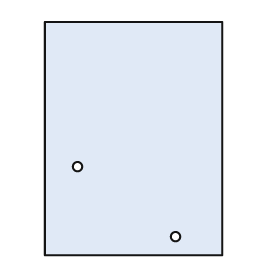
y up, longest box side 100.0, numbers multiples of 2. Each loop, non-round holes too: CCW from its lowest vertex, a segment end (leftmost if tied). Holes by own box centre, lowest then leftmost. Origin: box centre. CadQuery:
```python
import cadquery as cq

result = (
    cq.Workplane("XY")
    .moveTo(-38.0, -50.0)
    .lineTo(38.0, -50.0)
    .lineTo(38.0, 50.0)
    .lineTo(-38.0, 50.0)
    .close()
    .moveTo(18.0, -42.0)
    .circle(2.0)
    .moveTo(-24.0, -12.0)
    .circle(2.0)
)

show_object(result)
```